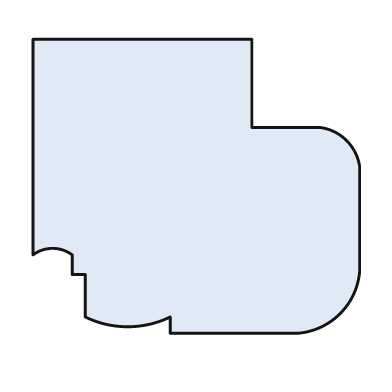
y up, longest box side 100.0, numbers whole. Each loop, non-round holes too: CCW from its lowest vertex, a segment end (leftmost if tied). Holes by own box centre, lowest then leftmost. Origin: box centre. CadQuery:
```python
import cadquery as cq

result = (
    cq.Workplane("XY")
    .moveTo(-8.0, -45.0)
    .lineTo(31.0, -45.0)
    .threePointArc((44.0, -39.0), (50.0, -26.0))
    .lineTo(50.0, 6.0)
    .threePointArc((46.0, 14.0), (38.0, 18.0))
    .lineTo(17.0, 18.0)
    .lineTo(17.0, 45.0)
    .lineTo(-50.0, 45.0)
    .lineTo(-50.0, -21.0)
    .threePointArc((-44.0, -19.0), (-38.0, -21.0))
    .lineTo(-38.0, -27.0)
    .lineTo(-34.0, -27.0)
    .lineTo(-34.0, -40.0)
    .threePointArc((-21.0, -43.0), (-8.0, -40.0))
    .close()
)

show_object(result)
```